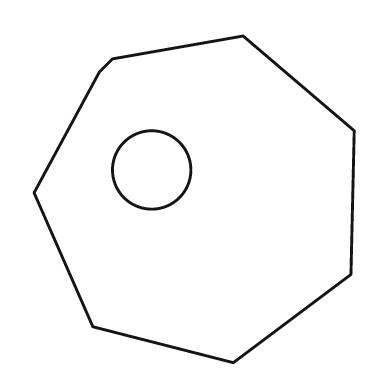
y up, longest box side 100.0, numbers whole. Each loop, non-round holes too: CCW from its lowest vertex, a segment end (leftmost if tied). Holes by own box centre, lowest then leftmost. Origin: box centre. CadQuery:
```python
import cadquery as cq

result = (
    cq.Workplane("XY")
    .moveTo(12.0, -50.0)
    .lineTo(48.0, -23.0)
    .lineTo(49.0, 21.0)
    .lineTo(15.0, 50.0)
    .lineTo(-25.0, 43.0)
    .lineTo(-29.0, 39.0)
    .lineTo(-49.0, 2.0)
    .lineTo(-31.0, -39.0)
    .close()
    .moveTo(-13.0, 9.0)
    .circle(12.0)
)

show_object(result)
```